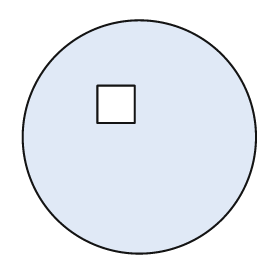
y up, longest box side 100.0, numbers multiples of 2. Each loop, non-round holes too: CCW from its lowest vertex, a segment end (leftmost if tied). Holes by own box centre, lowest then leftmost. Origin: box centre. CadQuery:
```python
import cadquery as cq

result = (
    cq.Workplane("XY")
    .moveTo(0.0, 0.0)
    .circle(50.0)
    .moveTo(-18.0, 6.0)
    .lineTo(-2.0, 6.0)
    .lineTo(-2.0, 22.0)
    .lineTo(-18.0, 22.0)
    .close()
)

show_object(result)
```